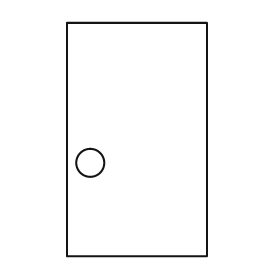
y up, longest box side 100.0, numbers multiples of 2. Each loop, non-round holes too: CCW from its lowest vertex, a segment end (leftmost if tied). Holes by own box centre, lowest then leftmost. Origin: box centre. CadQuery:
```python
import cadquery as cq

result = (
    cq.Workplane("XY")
    .moveTo(-30.0, -50.0)
    .lineTo(30.0, -50.0)
    .lineTo(30.0, 50.0)
    .lineTo(-30.0, 50.0)
    .close()
    .moveTo(-20.0, -10.0)
    .circle(6.0)
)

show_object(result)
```